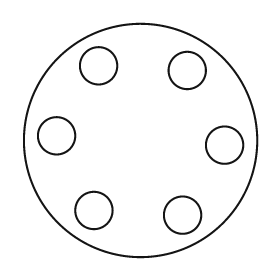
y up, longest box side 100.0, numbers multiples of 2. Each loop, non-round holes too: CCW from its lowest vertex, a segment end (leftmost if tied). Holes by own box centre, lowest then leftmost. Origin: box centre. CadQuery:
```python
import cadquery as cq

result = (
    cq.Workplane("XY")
    .moveTo(0.0, 0.0)
    .circle(50.0)
    .moveTo(18.0, -32.0)
    .circle(8.0)
    .moveTo(-20.0, -30.0)
    .circle(8.0)
    .moveTo(36.0, -2.0)
    .circle(8.0)
    .moveTo(-36.0, 2.0)
    .circle(8.0)
    .moveTo(20.0, 30.0)
    .circle(8.0)
    .moveTo(-18.0, 32.0)
    .circle(8.0)
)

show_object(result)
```